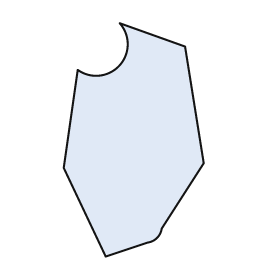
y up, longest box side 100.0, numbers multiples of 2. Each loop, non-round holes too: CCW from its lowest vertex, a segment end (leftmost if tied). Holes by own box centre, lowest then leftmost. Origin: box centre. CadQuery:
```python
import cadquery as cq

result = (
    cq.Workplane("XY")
    .moveTo(-12.0, -50.0)
    .lineTo(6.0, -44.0)
    .threePointArc((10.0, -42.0), (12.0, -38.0))
    .lineTo(30.0, -10.0)
    .lineTo(22.0, 40.0)
    .lineTo(-6.0, 50.0)
    .threePointArc((-6.0, 32.0), (-24.0, 30.0))
    .lineTo(-30.0, -12.0)
    .close()
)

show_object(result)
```